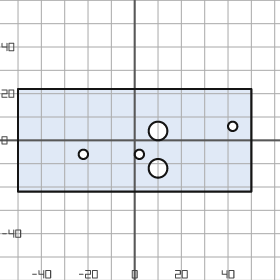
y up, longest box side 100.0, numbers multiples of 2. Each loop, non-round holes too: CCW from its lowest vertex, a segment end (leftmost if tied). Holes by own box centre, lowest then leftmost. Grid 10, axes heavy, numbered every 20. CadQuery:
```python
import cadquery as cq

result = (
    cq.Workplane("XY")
    .moveTo(-50.0, -22.0)
    .lineTo(50.0, -22.0)
    .lineTo(50.0, 22.0)
    .lineTo(-50.0, 22.0)
    .close()
    .moveTo(10.0, -12.0)
    .circle(4.0)
    .moveTo(-22.0, -6.0)
    .circle(2.0)
    .moveTo(2.0, -6.0)
    .circle(2.0)
    .moveTo(10.0, 4.0)
    .circle(4.0)
    .moveTo(42.0, 6.0)
    .circle(2.0)
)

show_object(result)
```